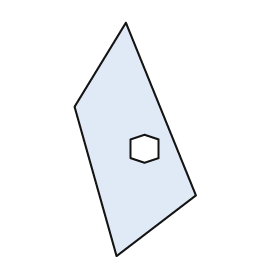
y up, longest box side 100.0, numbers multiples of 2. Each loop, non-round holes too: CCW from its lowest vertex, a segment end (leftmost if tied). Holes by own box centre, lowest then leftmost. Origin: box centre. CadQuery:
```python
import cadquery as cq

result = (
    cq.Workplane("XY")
    .moveTo(-8.0, -50.0)
    .lineTo(26.0, -24.0)
    .lineTo(-4.0, 50.0)
    .lineTo(-26.0, 14.0)
    .close()
    .moveTo(4.0, -10.0)
    .lineTo(10.0, -8.0)
    .lineTo(10.0, 0.0)
    .lineTo(4.0, 2.0)
    .lineTo(-2.0, 0.0)
    .lineTo(-2.0, -8.0)
    .close()
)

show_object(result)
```